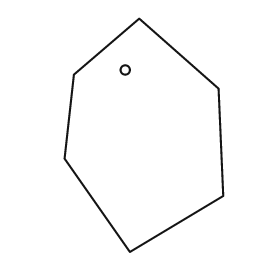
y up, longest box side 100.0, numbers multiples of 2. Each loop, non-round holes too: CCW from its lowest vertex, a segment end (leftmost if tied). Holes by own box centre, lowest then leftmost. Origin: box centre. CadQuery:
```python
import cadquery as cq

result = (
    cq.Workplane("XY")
    .moveTo(-6.0, -50.0)
    .lineTo(34.0, -26.0)
    .lineTo(32.0, 20.0)
    .lineTo(-2.0, 50.0)
    .lineTo(-30.0, 26.0)
    .lineTo(-34.0, -10.0)
    .close()
    .moveTo(-8.0, 28.0)
    .circle(2.0)
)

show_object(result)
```